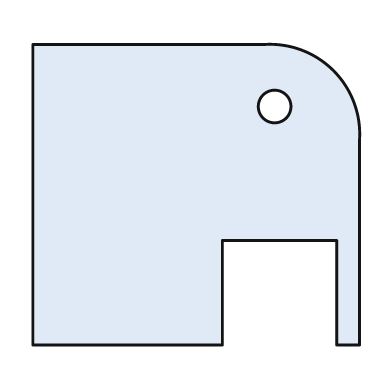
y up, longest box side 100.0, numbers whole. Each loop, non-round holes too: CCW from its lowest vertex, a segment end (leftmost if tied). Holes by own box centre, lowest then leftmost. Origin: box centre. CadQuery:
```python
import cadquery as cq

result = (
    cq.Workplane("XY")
    .moveTo(-50.0, -46.0)
    .lineTo(8.0, -46.0)
    .lineTo(8.0, -14.0)
    .lineTo(43.0, -14.0)
    .lineTo(43.0, -46.0)
    .lineTo(50.0, -46.0)
    .lineTo(50.0, 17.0)
    .threePointArc((42.0, 38.0), (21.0, 46.0))
    .lineTo(-50.0, 46.0)
    .close()
    .moveTo(24.0, 27.0)
    .circle(5.0)
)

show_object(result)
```